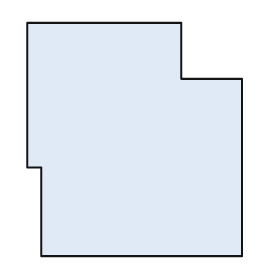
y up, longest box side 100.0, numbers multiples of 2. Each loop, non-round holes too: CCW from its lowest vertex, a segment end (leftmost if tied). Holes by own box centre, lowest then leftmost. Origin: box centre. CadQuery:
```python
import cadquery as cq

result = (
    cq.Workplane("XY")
    .moveTo(-40.0, -50.0)
    .lineTo(46.0, -50.0)
    .lineTo(46.0, 26.0)
    .lineTo(20.0, 26.0)
    .lineTo(20.0, 50.0)
    .lineTo(-46.0, 50.0)
    .lineTo(-46.0, -12.0)
    .lineTo(-40.0, -12.0)
    .close()
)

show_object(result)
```